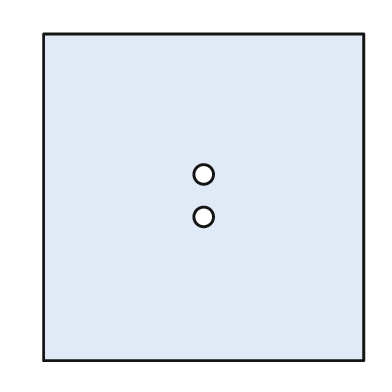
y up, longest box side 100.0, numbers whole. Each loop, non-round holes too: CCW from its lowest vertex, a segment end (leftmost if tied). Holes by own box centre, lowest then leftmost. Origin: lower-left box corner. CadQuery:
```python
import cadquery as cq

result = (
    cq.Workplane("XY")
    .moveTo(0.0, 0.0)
    .lineTo(98.0, 0.0)
    .lineTo(98.0, 100.0)
    .lineTo(0.0, 100.0)
    .close()
    .moveTo(49.0, 44.0)
    .circle(3.0)
    .moveTo(49.0, 57.0)
    .circle(3.0)
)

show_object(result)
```